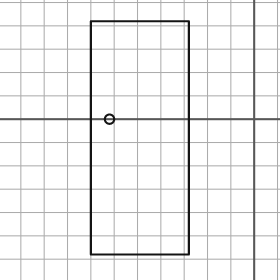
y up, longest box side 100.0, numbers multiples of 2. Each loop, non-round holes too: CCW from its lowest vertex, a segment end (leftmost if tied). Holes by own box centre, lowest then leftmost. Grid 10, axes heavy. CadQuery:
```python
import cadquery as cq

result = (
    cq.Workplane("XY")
    .moveTo(-70.0, -58.0)
    .lineTo(-28.0, -58.0)
    .lineTo(-28.0, 42.0)
    .lineTo(-70.0, 42.0)
    .close()
    .moveTo(-62.0, 0.0)
    .circle(2.0)
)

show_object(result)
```